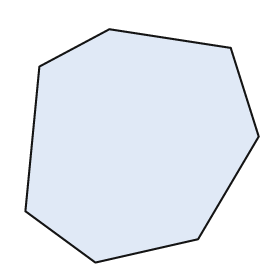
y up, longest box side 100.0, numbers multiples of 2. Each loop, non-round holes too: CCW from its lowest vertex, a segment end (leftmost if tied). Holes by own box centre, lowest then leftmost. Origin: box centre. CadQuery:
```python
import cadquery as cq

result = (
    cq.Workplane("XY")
    .moveTo(-20.0, -50.0)
    .lineTo(24.0, -40.0)
    .lineTo(50.0, 4.0)
    .lineTo(38.0, 42.0)
    .lineTo(-14.0, 50.0)
    .lineTo(-44.0, 34.0)
    .lineTo(-50.0, -28.0)
    .close()
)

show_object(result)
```